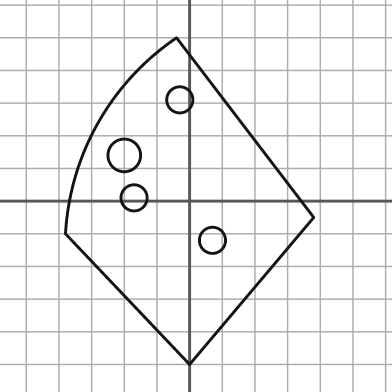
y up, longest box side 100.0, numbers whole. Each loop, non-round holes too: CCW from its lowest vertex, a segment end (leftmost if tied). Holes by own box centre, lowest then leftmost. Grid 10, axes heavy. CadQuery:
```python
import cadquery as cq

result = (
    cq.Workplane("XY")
    .moveTo(0.0, -50.0)
    .lineTo(38.0, -5.0)
    .lineTo(-4.0, 50.0)
    .threePointArc((-28.0, 24.0), (-38.0, -10.0))
    .close()
    .moveTo(7.0, -12.0)
    .circle(4.0)
    .moveTo(-17.0, 1.0)
    .circle(4.0)
    .moveTo(-20.0, 14.0)
    .circle(5.0)
    .moveTo(-3.0, 31.0)
    .circle(4.0)
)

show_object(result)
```